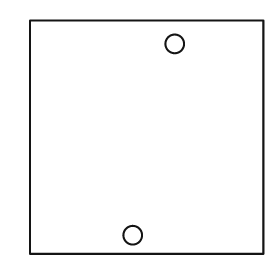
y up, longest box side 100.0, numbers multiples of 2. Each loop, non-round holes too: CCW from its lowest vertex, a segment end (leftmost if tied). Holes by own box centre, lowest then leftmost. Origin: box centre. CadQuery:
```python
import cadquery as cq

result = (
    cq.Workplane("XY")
    .moveTo(-50.0, -50.0)
    .lineTo(50.0, -50.0)
    .lineTo(50.0, 50.0)
    .lineTo(-50.0, 50.0)
    .close()
    .moveTo(-6.0, -42.0)
    .circle(4.0)
    .moveTo(12.0, 40.0)
    .circle(4.0)
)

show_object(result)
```